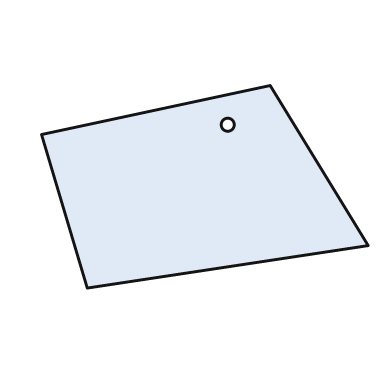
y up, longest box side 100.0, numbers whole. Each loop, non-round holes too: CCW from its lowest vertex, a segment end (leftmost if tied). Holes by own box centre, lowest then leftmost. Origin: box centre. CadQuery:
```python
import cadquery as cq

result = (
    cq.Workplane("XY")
    .moveTo(-36.0, -31.0)
    .lineTo(50.0, -18.0)
    .lineTo(20.0, 31.0)
    .lineTo(-50.0, 16.0)
    .close()
    .moveTo(7.0, 19.0)
    .circle(2.0)
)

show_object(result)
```